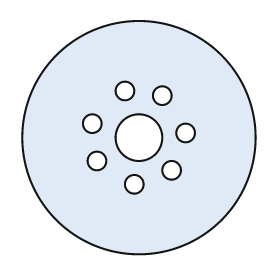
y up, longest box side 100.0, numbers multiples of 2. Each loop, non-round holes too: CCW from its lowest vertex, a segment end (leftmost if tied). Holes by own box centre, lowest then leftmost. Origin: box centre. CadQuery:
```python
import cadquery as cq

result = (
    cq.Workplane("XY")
    .moveTo(0.0, 0.0)
    .circle(50.0)
    .moveTo(-2.0, -20.0)
    .circle(4.0)
    .moveTo(14.0, -14.0)
    .circle(4.0)
    .moveTo(-18.0, -10.0)
    .circle(4.0)
    .moveTo(0.0, 0.0)
    .circle(10.0)
    .moveTo(20.0, 2.0)
    .circle(4.0)
    .moveTo(-20.0, 6.0)
    .circle(4.0)
    .moveTo(10.0, 18.0)
    .circle(4.0)
    .moveTo(-6.0, 20.0)
    .circle(4.0)
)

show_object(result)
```